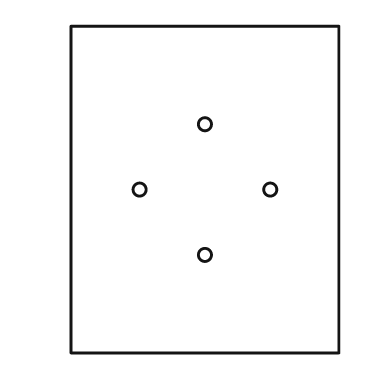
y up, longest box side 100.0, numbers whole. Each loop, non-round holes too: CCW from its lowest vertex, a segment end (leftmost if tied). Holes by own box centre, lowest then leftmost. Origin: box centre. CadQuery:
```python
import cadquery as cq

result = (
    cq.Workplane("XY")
    .moveTo(-41.0, -50.0)
    .lineTo(41.0, -50.0)
    .lineTo(41.0, 50.0)
    .lineTo(-41.0, 50.0)
    .close()
    .moveTo(0.0, -20.0)
    .circle(2.0)
    .moveTo(-20.0, 0.0)
    .circle(2.0)
    .moveTo(20.0, 0.0)
    .circle(2.0)
    .moveTo(0.0, 20.0)
    .circle(2.0)
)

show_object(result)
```